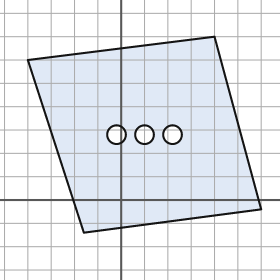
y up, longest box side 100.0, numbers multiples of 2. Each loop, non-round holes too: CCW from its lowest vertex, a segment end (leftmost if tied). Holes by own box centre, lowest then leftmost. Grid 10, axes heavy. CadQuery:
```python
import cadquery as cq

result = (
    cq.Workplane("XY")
    .moveTo(-16.0, -14.0)
    .lineTo(60.0, -4.0)
    .lineTo(40.0, 70.0)
    .lineTo(-40.0, 60.0)
    .close()
    .moveTo(-2.0, 28.0)
    .circle(4.0)
    .moveTo(10.0, 28.0)
    .circle(4.0)
    .moveTo(22.0, 28.0)
    .circle(4.0)
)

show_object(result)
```